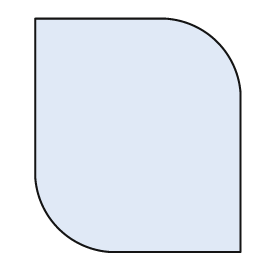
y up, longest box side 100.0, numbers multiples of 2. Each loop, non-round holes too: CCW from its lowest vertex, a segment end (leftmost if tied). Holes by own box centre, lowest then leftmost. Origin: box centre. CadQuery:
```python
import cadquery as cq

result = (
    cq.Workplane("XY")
    .moveTo(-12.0, -50.0)
    .lineTo(44.0, -50.0)
    .lineTo(44.0, 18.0)
    .threePointArc((34.0, 40.0), (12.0, 50.0))
    .lineTo(-44.0, 50.0)
    .lineTo(-44.0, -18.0)
    .threePointArc((-34.0, -40.0), (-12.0, -50.0))
    .close()
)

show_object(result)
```